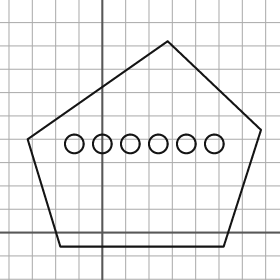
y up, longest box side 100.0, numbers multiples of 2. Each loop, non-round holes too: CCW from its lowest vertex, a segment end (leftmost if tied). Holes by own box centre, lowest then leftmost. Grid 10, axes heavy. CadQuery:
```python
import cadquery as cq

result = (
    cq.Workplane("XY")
    .moveTo(-18.0, -6.0)
    .lineTo(52.0, -6.0)
    .lineTo(68.0, 44.0)
    .lineTo(28.0, 82.0)
    .lineTo(-32.0, 40.0)
    .close()
    .moveTo(-12.0, 38.0)
    .circle(4.0)
    .moveTo(0.0, 38.0)
    .circle(4.0)
    .moveTo(12.0, 38.0)
    .circle(4.0)
    .moveTo(24.0, 38.0)
    .circle(4.0)
    .moveTo(36.0, 38.0)
    .circle(4.0)
    .moveTo(48.0, 38.0)
    .circle(4.0)
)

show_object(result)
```